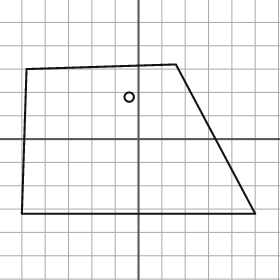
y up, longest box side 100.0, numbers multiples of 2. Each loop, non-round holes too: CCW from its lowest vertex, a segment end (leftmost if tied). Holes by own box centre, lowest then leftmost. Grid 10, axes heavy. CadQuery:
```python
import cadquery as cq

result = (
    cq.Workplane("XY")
    .moveTo(-50.0, -32.0)
    .lineTo(50.0, -32.0)
    .lineTo(16.0, 32.0)
    .lineTo(-48.0, 30.0)
    .close()
    .moveTo(-4.0, 18.0)
    .circle(2.0)
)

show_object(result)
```